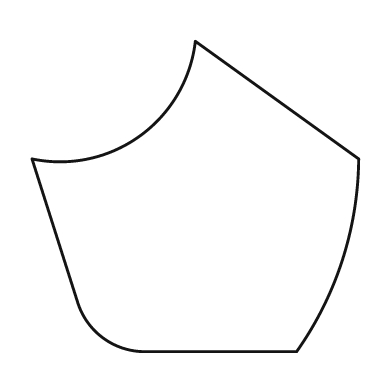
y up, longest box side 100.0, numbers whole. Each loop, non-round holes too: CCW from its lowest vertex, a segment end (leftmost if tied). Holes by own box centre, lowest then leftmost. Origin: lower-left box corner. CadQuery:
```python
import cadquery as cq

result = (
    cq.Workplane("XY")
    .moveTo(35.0, 0.0)
    .lineTo(81.0, 0.0)
    .threePointArc((95.0, 28.0), (100.0, 59.0))
    .lineTo(50.0, 95.0)
    .threePointArc((33.0, 66.0), (0.0, 59.0))
    .lineTo(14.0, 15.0)
    .threePointArc((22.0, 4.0), (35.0, 0.0))
    .close()
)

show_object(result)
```